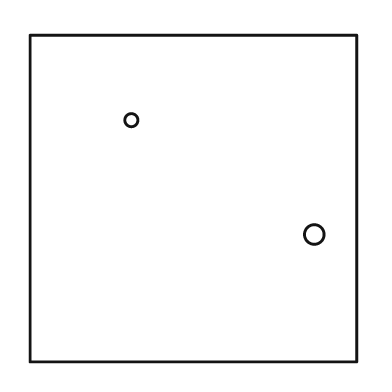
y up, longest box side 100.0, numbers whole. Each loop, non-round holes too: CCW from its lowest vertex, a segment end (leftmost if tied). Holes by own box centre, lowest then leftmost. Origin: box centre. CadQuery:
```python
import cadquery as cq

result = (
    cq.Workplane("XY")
    .moveTo(-50.0, -50.0)
    .lineTo(50.0, -50.0)
    .lineTo(50.0, 50.0)
    .lineTo(-50.0, 50.0)
    .close()
    .moveTo(37.0, -11.0)
    .circle(3.0)
    .moveTo(-19.0, 24.0)
    .circle(2.0)
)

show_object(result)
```